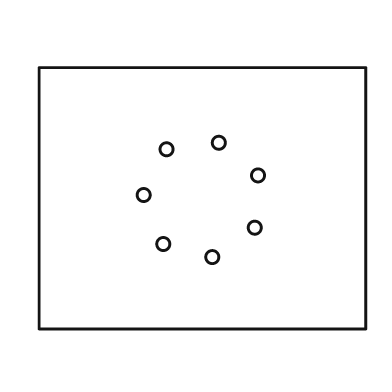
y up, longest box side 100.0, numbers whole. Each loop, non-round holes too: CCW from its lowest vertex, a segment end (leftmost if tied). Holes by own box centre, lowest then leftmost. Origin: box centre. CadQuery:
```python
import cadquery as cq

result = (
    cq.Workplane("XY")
    .moveTo(-50.0, -40.0)
    .lineTo(50.0, -40.0)
    .lineTo(50.0, 40.0)
    .lineTo(-50.0, 40.0)
    .close()
    .moveTo(3.0, -18.0)
    .circle(2.0)
    .moveTo(-12.0, -14.0)
    .circle(2.0)
    .moveTo(16.0, -9.0)
    .circle(2.0)
    .moveTo(-18.0, 1.0)
    .circle(2.0)
    .moveTo(17.0, 7.0)
    .circle(2.0)
    .moveTo(-11.0, 15.0)
    .circle(2.0)
    .moveTo(5.0, 17.0)
    .circle(2.0)
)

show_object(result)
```